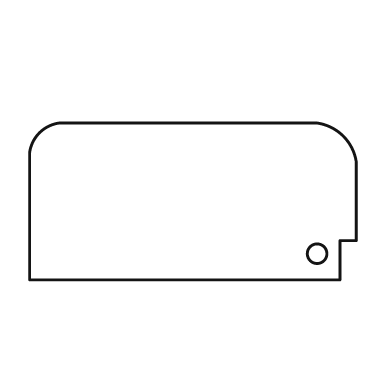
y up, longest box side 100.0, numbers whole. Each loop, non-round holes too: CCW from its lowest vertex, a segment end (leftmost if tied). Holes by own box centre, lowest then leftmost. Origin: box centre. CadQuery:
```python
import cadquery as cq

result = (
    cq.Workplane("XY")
    .moveTo(-50.0, -24.0)
    .lineTo(45.0, -24.0)
    .lineTo(45.0, -12.0)
    .lineTo(50.0, -12.0)
    .lineTo(50.0, 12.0)
    .threePointArc((46.0, 20.0), (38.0, 24.0))
    .lineTo(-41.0, 24.0)
    .threePointArc((-47.0, 21.0), (-50.0, 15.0))
    .close()
    .moveTo(38.0, -16.0)
    .circle(3.0)
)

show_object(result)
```